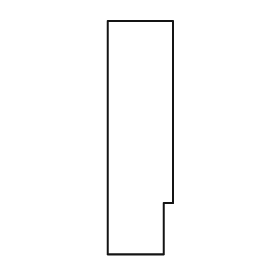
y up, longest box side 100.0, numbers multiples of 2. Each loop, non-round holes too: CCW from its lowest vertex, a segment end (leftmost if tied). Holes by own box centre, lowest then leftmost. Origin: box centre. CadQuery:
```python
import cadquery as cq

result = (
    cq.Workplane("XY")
    .moveTo(-14.0, -50.0)
    .lineTo(10.0, -50.0)
    .lineTo(10.0, -28.0)
    .lineTo(14.0, -28.0)
    .lineTo(14.0, 50.0)
    .lineTo(-14.0, 50.0)
    .close()
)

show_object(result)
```